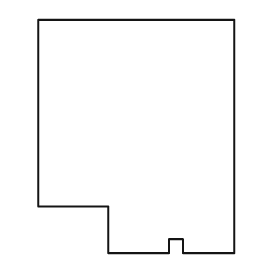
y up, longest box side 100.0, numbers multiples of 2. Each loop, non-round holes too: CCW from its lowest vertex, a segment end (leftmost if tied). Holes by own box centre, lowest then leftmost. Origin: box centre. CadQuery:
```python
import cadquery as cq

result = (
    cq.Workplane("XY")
    .moveTo(-12.0, -50.0)
    .lineTo(14.0, -50.0)
    .lineTo(14.0, -44.0)
    .lineTo(20.0, -44.0)
    .lineTo(20.0, -50.0)
    .lineTo(42.0, -50.0)
    .lineTo(42.0, 50.0)
    .lineTo(-42.0, 50.0)
    .lineTo(-42.0, -30.0)
    .lineTo(-12.0, -30.0)
    .close()
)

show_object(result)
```